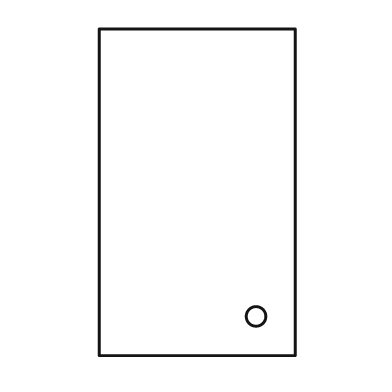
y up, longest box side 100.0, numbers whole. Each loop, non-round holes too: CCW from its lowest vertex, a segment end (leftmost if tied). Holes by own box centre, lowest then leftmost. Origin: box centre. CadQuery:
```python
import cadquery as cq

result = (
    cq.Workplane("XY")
    .moveTo(-30.0, -50.0)
    .lineTo(30.0, -50.0)
    .lineTo(30.0, 50.0)
    .lineTo(-30.0, 50.0)
    .close()
    .moveTo(18.0, -38.0)
    .circle(3.0)
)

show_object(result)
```